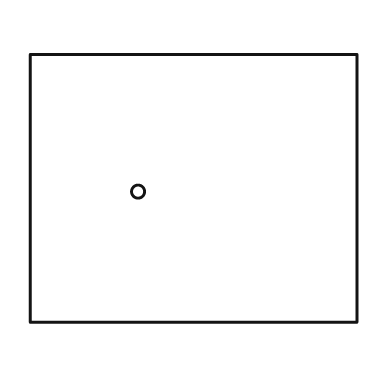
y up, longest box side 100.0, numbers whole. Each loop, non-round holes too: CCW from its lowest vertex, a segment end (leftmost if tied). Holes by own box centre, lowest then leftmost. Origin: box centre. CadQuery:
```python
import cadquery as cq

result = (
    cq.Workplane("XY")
    .moveTo(-50.0, -41.0)
    .lineTo(50.0, -41.0)
    .lineTo(50.0, 41.0)
    .lineTo(-50.0, 41.0)
    .close()
    .moveTo(-17.0, -1.0)
    .circle(2.0)
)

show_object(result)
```